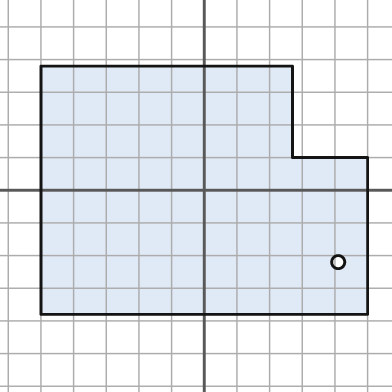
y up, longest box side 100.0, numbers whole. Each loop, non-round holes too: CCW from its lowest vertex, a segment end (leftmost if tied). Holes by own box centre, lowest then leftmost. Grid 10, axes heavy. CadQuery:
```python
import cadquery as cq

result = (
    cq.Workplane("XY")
    .moveTo(-50.0, -38.0)
    .lineTo(50.0, -38.0)
    .lineTo(50.0, 10.0)
    .lineTo(27.0, 10.0)
    .lineTo(27.0, 38.0)
    .lineTo(-50.0, 38.0)
    .close()
    .moveTo(41.0, -22.0)
    .circle(2.0)
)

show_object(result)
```